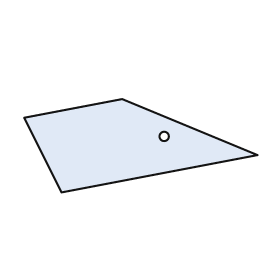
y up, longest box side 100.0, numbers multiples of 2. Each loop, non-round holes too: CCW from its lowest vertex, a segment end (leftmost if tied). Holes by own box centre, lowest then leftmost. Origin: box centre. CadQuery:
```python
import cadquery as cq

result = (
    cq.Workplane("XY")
    .moveTo(-34.0, -20.0)
    .lineTo(50.0, -4.0)
    .lineTo(-8.0, 20.0)
    .lineTo(-50.0, 12.0)
    .close()
    .moveTo(10.0, 4.0)
    .circle(2.0)
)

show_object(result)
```